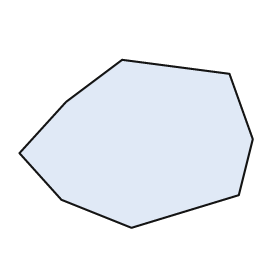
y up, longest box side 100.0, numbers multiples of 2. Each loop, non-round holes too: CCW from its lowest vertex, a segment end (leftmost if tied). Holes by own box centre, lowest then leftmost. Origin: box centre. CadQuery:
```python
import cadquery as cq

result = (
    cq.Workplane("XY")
    .moveTo(-2.0, -36.0)
    .lineTo(44.0, -22.0)
    .lineTo(50.0, 2.0)
    .lineTo(40.0, 30.0)
    .lineTo(-6.0, 36.0)
    .lineTo(-30.0, 18.0)
    .lineTo(-50.0, -4.0)
    .lineTo(-32.0, -24.0)
    .close()
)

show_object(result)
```